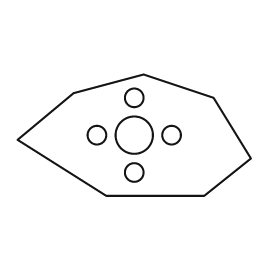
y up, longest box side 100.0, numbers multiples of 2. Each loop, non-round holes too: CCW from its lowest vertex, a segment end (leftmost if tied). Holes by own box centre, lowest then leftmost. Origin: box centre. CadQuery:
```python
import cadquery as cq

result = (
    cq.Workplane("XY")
    .moveTo(-12.0, -26.0)
    .lineTo(30.0, -26.0)
    .lineTo(50.0, -10.0)
    .lineTo(34.0, 16.0)
    .lineTo(4.0, 26.0)
    .lineTo(-26.0, 18.0)
    .lineTo(-50.0, -2.0)
    .close()
    .moveTo(0.0, -16.0)
    .circle(4.0)
    .moveTo(-16.0, 0.0)
    .circle(4.0)
    .moveTo(0.0, 0.0)
    .circle(8.0)
    .moveTo(16.0, 0.0)
    .circle(4.0)
    .moveTo(0.0, 16.0)
    .circle(4.0)
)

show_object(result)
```